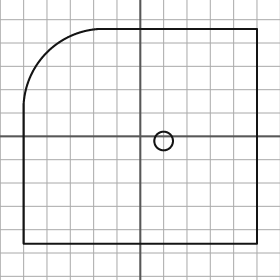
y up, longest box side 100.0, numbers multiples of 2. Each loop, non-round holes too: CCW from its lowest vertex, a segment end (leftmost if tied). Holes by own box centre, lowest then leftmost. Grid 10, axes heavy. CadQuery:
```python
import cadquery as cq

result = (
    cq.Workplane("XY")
    .moveTo(-50.0, -46.0)
    .lineTo(50.0, -46.0)
    .lineTo(50.0, 46.0)
    .lineTo(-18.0, 46.0)
    .threePointArc((-40.0, 36.0), (-50.0, 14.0))
    .close()
    .moveTo(10.0, -2.0)
    .circle(4.0)
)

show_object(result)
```